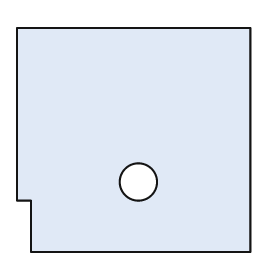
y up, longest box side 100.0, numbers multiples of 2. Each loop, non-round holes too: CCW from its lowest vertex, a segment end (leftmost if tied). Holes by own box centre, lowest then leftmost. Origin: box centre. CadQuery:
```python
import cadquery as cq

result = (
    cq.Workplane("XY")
    .moveTo(-44.0, -48.0)
    .lineTo(50.0, -48.0)
    .lineTo(50.0, 48.0)
    .lineTo(-50.0, 48.0)
    .lineTo(-50.0, -26.0)
    .lineTo(-44.0, -26.0)
    .close()
    .moveTo(2.0, -18.0)
    .circle(8.0)
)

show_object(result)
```